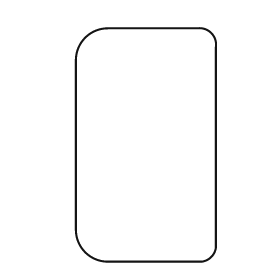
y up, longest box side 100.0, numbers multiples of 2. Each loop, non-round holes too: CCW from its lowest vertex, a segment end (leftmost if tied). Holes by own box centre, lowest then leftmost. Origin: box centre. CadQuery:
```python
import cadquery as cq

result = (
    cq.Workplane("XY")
    .moveTo(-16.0, -50.0)
    .lineTo(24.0, -50.0)
    .threePointArc((28.0, -48.0), (30.0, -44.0))
    .lineTo(30.0, 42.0)
    .threePointArc((28.0, 48.0), (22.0, 50.0))
    .lineTo(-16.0, 50.0)
    .threePointArc((-26.0, 46.0), (-30.0, 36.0))
    .lineTo(-30.0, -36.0)
    .threePointArc((-26.0, -46.0), (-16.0, -50.0))
    .close()
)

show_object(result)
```